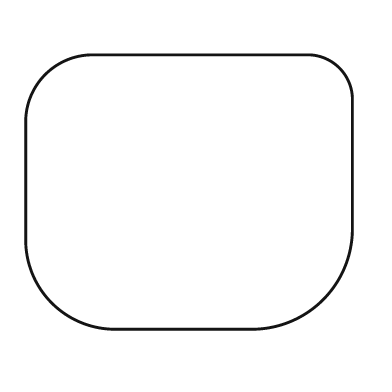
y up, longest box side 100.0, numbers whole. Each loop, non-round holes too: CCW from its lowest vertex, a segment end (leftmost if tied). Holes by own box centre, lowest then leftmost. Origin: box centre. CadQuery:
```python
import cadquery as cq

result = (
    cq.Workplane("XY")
    .moveTo(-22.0, -42.0)
    .lineTo(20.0, -42.0)
    .threePointArc((41.0, -33.0), (50.0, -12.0))
    .lineTo(50.0, 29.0)
    .threePointArc((46.0, 38.0), (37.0, 42.0))
    .lineTo(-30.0, 42.0)
    .threePointArc((-44.0, 36.0), (-50.0, 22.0))
    .lineTo(-50.0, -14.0)
    .threePointArc((-42.0, -34.0), (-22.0, -42.0))
    .close()
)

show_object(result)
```